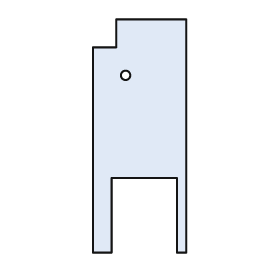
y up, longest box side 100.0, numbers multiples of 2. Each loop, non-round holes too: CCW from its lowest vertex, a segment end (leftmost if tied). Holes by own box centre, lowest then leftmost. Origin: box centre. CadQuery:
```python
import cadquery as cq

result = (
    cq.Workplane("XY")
    .moveTo(-20.0, -50.0)
    .lineTo(-12.0, -50.0)
    .lineTo(-12.0, -18.0)
    .lineTo(16.0, -18.0)
    .lineTo(16.0, -50.0)
    .lineTo(20.0, -50.0)
    .lineTo(20.0, 50.0)
    .lineTo(-10.0, 50.0)
    .lineTo(-10.0, 38.0)
    .lineTo(-20.0, 38.0)
    .close()
    .moveTo(-6.0, 26.0)
    .circle(2.0)
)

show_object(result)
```